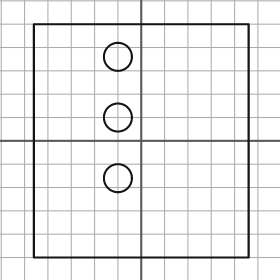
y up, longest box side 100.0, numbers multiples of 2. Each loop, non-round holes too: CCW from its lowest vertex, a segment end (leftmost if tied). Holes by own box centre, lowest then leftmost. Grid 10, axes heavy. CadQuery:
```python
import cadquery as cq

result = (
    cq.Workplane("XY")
    .moveTo(-46.0, -50.0)
    .lineTo(46.0, -50.0)
    .lineTo(46.0, 50.0)
    .lineTo(-46.0, 50.0)
    .close()
    .moveTo(-10.0, -16.0)
    .circle(6.0)
    .moveTo(-10.0, 10.0)
    .circle(6.0)
    .moveTo(-10.0, 36.0)
    .circle(6.0)
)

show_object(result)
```